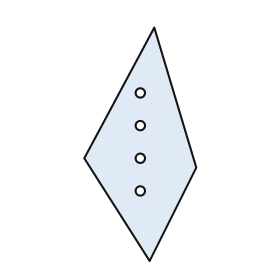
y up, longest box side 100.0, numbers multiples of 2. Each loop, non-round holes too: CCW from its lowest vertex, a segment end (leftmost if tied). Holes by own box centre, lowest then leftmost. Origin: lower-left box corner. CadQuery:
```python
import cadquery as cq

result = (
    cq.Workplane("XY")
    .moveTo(28.0, 0.0)
    .lineTo(48.0, 40.0)
    .lineTo(30.0, 100.0)
    .lineTo(0.0, 44.0)
    .close()
    .moveTo(24.0, 30.0)
    .circle(2.0)
    .moveTo(24.0, 44.0)
    .circle(2.0)
    .moveTo(24.0, 58.0)
    .circle(2.0)
    .moveTo(24.0, 72.0)
    .circle(2.0)
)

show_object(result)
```